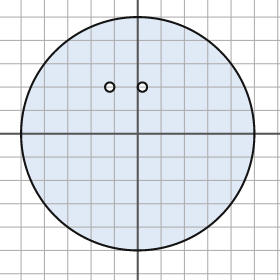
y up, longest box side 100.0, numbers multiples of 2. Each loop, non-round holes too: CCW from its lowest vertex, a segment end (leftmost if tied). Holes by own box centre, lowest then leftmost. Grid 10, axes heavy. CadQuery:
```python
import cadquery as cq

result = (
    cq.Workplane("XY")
    .moveTo(0.0, 0.0)
    .circle(50.0)
    .moveTo(-12.0, 20.0)
    .circle(2.0)
    .moveTo(2.0, 20.0)
    .circle(2.0)
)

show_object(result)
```